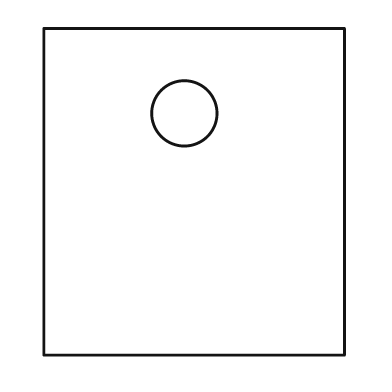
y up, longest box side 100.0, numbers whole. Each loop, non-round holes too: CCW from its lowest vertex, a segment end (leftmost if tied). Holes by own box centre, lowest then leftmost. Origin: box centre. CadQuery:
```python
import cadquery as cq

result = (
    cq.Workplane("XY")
    .moveTo(-46.0, -50.0)
    .lineTo(46.0, -50.0)
    .lineTo(46.0, 50.0)
    .lineTo(-46.0, 50.0)
    .close()
    .moveTo(-3.0, 24.0)
    .circle(10.0)
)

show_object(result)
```